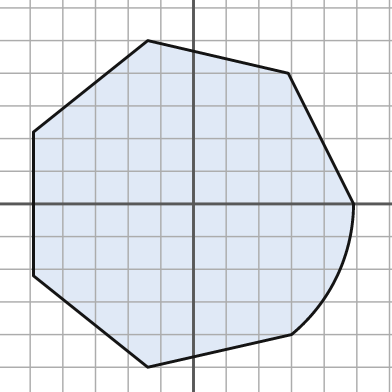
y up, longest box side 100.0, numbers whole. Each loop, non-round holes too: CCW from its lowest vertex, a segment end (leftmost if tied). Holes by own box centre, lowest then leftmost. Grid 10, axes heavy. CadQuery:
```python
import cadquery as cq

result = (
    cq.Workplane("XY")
    .moveTo(-14.0, -50.0)
    .lineTo(30.0, -40.0)
    .threePointArc((44.0, -22.0), (49.0, 0.0))
    .lineTo(29.0, 40.0)
    .lineTo(-14.0, 50.0)
    .lineTo(-49.0, 22.0)
    .lineTo(-49.0, -22.0)
    .close()
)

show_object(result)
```